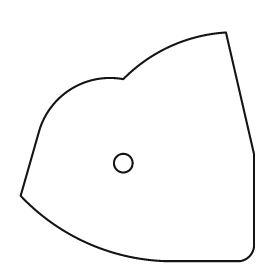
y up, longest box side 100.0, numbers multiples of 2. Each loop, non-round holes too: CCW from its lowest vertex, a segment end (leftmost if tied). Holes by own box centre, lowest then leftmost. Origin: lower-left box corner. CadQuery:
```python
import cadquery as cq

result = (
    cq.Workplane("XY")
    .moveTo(62.0, 0.0)
    .lineTo(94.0, 0.0)
    .threePointArc((98.0, 2.0), (100.0, 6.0))
    .lineTo(100.0, 46.0)
    .lineTo(88.0, 98.0)
    .threePointArc((64.0, 92.0), (44.0, 78.0))
    .threePointArc((22.0, 74.0), (8.0, 56.0))
    .lineTo(0.0, 28.0)
    .threePointArc((28.0, 8.0), (62.0, 0.0))
    .close()
    .moveTo(44.0, 42.0)
    .circle(4.0)
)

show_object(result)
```